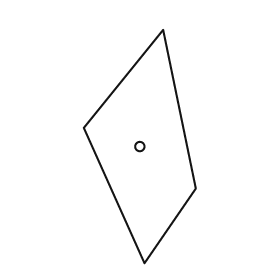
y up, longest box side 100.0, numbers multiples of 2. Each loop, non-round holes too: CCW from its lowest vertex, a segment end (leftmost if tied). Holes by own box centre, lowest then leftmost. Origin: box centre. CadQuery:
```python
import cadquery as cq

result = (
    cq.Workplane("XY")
    .moveTo(2.0, -50.0)
    .lineTo(24.0, -18.0)
    .lineTo(10.0, 50.0)
    .lineTo(-24.0, 8.0)
    .close()
    .moveTo(0.0, 0.0)
    .circle(2.0)
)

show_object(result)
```